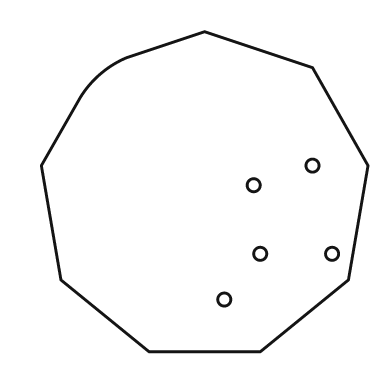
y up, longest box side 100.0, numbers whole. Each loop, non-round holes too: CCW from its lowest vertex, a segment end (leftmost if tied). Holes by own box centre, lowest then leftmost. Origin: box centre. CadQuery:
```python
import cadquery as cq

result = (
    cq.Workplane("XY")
    .moveTo(-17.0, -49.0)
    .lineTo(17.0, -49.0)
    .lineTo(44.0, -27.0)
    .lineTo(50.0, 8.0)
    .lineTo(33.0, 38.0)
    .lineTo(0.0, 49.0)
    .lineTo(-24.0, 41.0)
    .threePointArc((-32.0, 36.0), (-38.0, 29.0))
    .lineTo(-50.0, 8.0)
    .lineTo(-44.0, -27.0)
    .close()
    .moveTo(6.0, -33.0)
    .circle(2.0)
    .moveTo(17.0, -19.0)
    .circle(2.0)
    .moveTo(39.0, -19.0)
    .circle(2.0)
    .moveTo(15.0, 2.0)
    .circle(2.0)
    .moveTo(33.0, 8.0)
    .circle(2.0)
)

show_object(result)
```